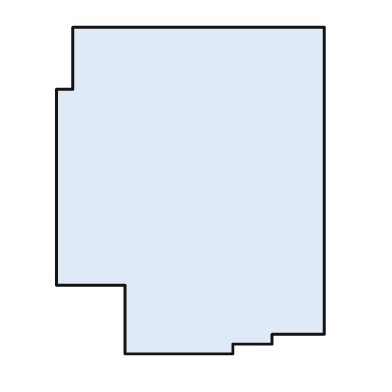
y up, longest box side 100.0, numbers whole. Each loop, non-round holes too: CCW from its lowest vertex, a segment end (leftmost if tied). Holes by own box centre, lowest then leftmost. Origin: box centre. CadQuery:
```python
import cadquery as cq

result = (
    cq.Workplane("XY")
    .moveTo(-20.0, -50.0)
    .lineTo(13.0, -50.0)
    .lineTo(13.0, -47.0)
    .lineTo(25.0, -47.0)
    .lineTo(25.0, -44.0)
    .lineTo(41.0, -44.0)
    .lineTo(41.0, 50.0)
    .lineTo(-36.0, 50.0)
    .lineTo(-36.0, 31.0)
    .lineTo(-41.0, 31.0)
    .lineTo(-41.0, -29.0)
    .lineTo(-20.0, -29.0)
    .close()
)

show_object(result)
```